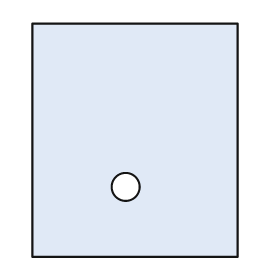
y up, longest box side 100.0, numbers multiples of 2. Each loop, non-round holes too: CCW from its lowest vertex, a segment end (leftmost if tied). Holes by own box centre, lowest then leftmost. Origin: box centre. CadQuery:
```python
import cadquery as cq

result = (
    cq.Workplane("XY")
    .moveTo(-44.0, -50.0)
    .lineTo(44.0, -50.0)
    .lineTo(44.0, 50.0)
    .lineTo(-44.0, 50.0)
    .close()
    .moveTo(-4.0, -20.0)
    .circle(6.0)
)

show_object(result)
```